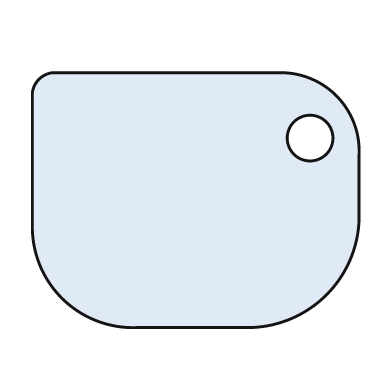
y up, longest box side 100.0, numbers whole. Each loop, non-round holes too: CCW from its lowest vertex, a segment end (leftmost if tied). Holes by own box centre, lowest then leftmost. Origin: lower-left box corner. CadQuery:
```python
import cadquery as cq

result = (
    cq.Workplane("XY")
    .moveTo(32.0, 0.0)
    .lineTo(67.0, 0.0)
    .threePointArc((90.0, 10.0), (100.0, 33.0))
    .lineTo(100.0, 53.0)
    .threePointArc((93.0, 71.0), (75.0, 78.0))
    .lineTo(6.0, 78.0)
    .threePointArc((2.0, 76.0), (0.0, 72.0))
    .lineTo(0.0, 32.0)
    .threePointArc((9.0, 9.0), (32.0, 0.0))
    .close()
    .moveTo(85.0, 58.0)
    .circle(7.0)
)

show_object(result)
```